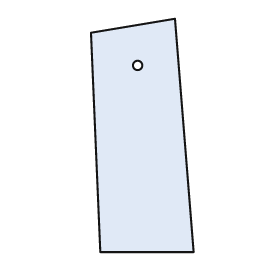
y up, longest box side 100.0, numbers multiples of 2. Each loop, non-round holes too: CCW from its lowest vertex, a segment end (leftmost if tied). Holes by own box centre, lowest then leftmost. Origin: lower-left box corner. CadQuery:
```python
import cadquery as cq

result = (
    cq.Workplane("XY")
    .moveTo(4.0, 0.0)
    .lineTo(44.0, 0.0)
    .lineTo(36.0, 100.0)
    .lineTo(0.0, 94.0)
    .close()
    .moveTo(20.0, 80.0)
    .circle(2.0)
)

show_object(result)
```